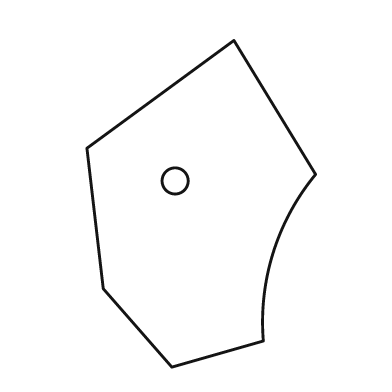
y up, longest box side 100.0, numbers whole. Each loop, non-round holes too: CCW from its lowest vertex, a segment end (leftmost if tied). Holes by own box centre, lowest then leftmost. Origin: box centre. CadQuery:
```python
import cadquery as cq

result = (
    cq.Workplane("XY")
    .moveTo(-9.0, -50.0)
    .lineTo(19.0, -42.0)
    .threePointArc((22.0, -15.0), (35.0, 9.0))
    .lineTo(10.0, 50.0)
    .lineTo(-35.0, 17.0)
    .lineTo(-30.0, -26.0)
    .close()
    .moveTo(-8.0, 7.0)
    .circle(4.0)
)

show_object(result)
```